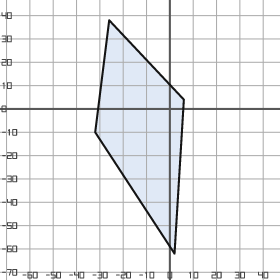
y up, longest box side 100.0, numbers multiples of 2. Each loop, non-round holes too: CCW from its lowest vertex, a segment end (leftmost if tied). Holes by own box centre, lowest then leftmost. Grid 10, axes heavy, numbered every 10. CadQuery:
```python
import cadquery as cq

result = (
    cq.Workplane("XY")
    .moveTo(2.0, -62.0)
    .lineTo(6.0, 4.0)
    .lineTo(-26.0, 38.0)
    .lineTo(-32.0, -10.0)
    .close()
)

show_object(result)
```